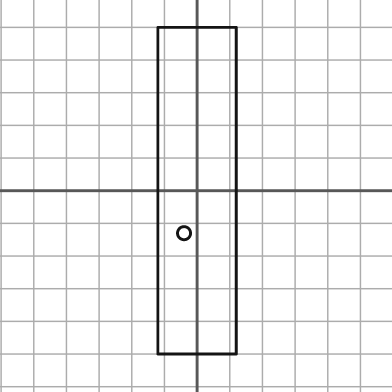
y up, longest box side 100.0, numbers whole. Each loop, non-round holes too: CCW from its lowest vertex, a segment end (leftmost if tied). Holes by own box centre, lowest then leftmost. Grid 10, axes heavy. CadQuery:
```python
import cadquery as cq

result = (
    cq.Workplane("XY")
    .moveTo(-12.0, -50.0)
    .lineTo(12.0, -50.0)
    .lineTo(12.0, 50.0)
    .lineTo(-12.0, 50.0)
    .close()
    .moveTo(-4.0, -13.0)
    .circle(2.0)
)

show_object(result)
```